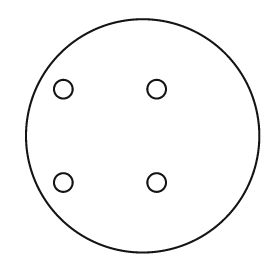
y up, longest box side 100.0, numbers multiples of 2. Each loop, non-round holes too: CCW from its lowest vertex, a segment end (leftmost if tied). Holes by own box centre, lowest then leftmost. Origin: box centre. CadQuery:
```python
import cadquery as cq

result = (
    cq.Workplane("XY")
    .moveTo(0.0, 0.0)
    .circle(50.0)
    .moveTo(-34.0, -20.0)
    .circle(4.0)
    .moveTo(6.0, -20.0)
    .circle(4.0)
    .moveTo(-34.0, 20.0)
    .circle(4.0)
    .moveTo(6.0, 20.0)
    .circle(4.0)
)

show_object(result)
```